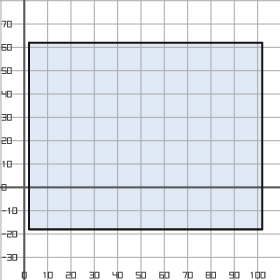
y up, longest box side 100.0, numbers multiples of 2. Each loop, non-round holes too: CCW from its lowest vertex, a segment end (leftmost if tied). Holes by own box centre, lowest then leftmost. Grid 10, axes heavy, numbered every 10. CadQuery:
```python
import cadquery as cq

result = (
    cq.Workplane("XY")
    .moveTo(2.0, -18.0)
    .lineTo(102.0, -18.0)
    .lineTo(102.0, 62.0)
    .lineTo(2.0, 62.0)
    .close()
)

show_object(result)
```